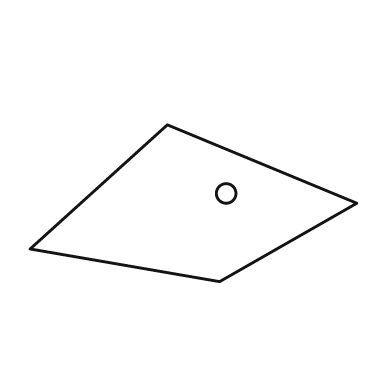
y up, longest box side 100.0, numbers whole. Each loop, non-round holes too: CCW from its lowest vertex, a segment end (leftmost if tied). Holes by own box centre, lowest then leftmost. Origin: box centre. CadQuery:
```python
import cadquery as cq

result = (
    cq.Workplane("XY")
    .moveTo(8.0, -24.0)
    .lineTo(50.0, 0.0)
    .lineTo(-8.0, 24.0)
    .lineTo(-50.0, -14.0)
    .close()
    .moveTo(10.0, 3.0)
    .circle(3.0)
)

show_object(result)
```